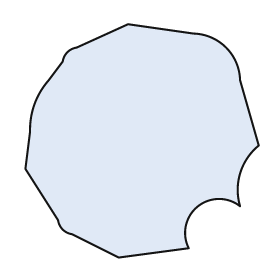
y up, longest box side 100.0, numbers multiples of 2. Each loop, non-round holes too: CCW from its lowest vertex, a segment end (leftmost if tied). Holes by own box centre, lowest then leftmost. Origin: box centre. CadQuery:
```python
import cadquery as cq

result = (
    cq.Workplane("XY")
    .moveTo(-10.0, -50.0)
    .lineTo(20.0, -46.0)
    .threePointArc((24.0, -28.0), (42.0, -28.0))
    .threePointArc((42.0, -14.0), (50.0, -2.0))
    .lineTo(42.0, 26.0)
    .threePointArc((36.0, 40.0), (22.0, 46.0))
    .lineTo(-6.0, 50.0)
    .lineTo(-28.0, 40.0)
    .threePointArc((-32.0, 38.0), (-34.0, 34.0))
    .lineTo(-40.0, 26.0)
    .threePointArc((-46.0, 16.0), (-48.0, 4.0))
    .lineTo(-50.0, -12.0)
    .lineTo(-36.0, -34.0)
    .threePointArc((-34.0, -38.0), (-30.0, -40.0))
    .close()
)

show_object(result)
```